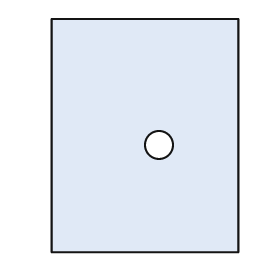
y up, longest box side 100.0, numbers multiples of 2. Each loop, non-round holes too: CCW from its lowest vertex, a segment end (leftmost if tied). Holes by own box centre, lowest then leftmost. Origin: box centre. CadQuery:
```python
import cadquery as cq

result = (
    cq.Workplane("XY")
    .moveTo(-40.0, -50.0)
    .lineTo(40.0, -50.0)
    .lineTo(40.0, 50.0)
    .lineTo(-40.0, 50.0)
    .close()
    .moveTo(6.0, -4.0)
    .circle(6.0)
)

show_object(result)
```